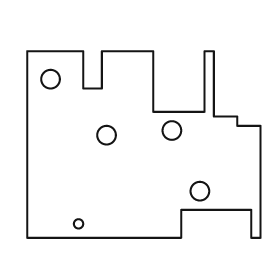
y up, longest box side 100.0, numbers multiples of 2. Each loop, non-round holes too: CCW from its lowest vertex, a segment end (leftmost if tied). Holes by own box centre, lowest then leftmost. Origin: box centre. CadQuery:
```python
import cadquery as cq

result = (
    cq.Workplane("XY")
    .moveTo(-50.0, -40.0)
    .lineTo(16.0, -40.0)
    .lineTo(16.0, -28.0)
    .lineTo(46.0, -28.0)
    .lineTo(46.0, -40.0)
    .lineTo(50.0, -40.0)
    .lineTo(50.0, 8.0)
    .lineTo(40.0, 8.0)
    .lineTo(40.0, 12.0)
    .lineTo(30.0, 12.0)
    .lineTo(30.0, 40.0)
    .lineTo(26.0, 40.0)
    .lineTo(26.0, 14.0)
    .lineTo(4.0, 14.0)
    .lineTo(4.0, 40.0)
    .lineTo(-18.0, 40.0)
    .lineTo(-18.0, 24.0)
    .lineTo(-26.0, 24.0)
    .lineTo(-26.0, 40.0)
    .lineTo(-50.0, 40.0)
    .close()
    .moveTo(-28.0, -34.0)
    .circle(2.0)
    .moveTo(24.0, -20.0)
    .circle(4.0)
    .moveTo(-16.0, 4.0)
    .circle(4.0)
    .moveTo(12.0, 6.0)
    .circle(4.0)
    .moveTo(-40.0, 28.0)
    .circle(4.0)
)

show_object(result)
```